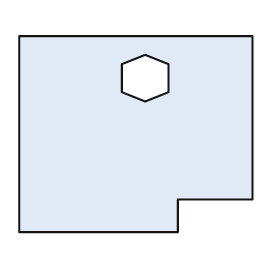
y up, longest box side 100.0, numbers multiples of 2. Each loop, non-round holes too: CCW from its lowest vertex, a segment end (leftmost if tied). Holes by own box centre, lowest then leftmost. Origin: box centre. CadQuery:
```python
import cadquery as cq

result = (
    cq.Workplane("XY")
    .moveTo(-50.0, -42.0)
    .lineTo(18.0, -42.0)
    .lineTo(18.0, -28.0)
    .lineTo(50.0, -28.0)
    .lineTo(50.0, 42.0)
    .lineTo(-50.0, 42.0)
    .close()
    .moveTo(4.0, 14.0)
    .lineTo(14.0, 18.0)
    .lineTo(14.0, 30.0)
    .lineTo(4.0, 34.0)
    .lineTo(-6.0, 30.0)
    .lineTo(-6.0, 18.0)
    .close()
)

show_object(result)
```